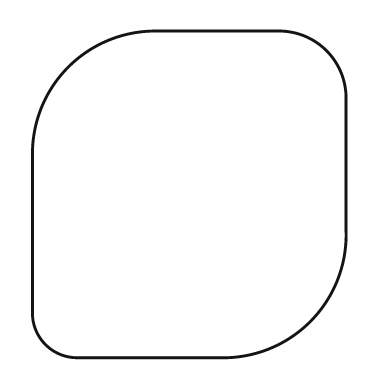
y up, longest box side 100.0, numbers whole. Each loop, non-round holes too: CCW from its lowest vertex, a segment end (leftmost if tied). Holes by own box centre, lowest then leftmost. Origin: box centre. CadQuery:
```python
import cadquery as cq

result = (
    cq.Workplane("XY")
    .moveTo(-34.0, -50.0)
    .lineTo(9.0, -50.0)
    .threePointArc((37.0, -39.0), (48.0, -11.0))
    .lineTo(48.0, 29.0)
    .threePointArc((42.0, 44.0), (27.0, 50.0))
    .lineTo(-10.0, 50.0)
    .threePointArc((-37.0, 39.0), (-48.0, 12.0))
    .lineTo(-48.0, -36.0)
    .threePointArc((-44.0, -46.0), (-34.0, -50.0))
    .close()
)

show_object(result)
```